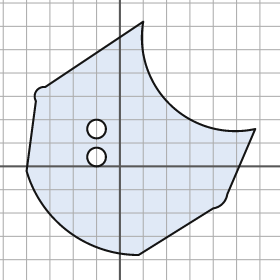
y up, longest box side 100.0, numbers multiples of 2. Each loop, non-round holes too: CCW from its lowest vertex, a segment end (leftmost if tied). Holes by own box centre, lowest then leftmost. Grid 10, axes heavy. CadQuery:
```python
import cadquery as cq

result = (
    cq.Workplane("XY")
    .moveTo(8.0, -38.0)
    .lineTo(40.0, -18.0)
    .threePointArc((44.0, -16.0), (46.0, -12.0))
    .lineTo(58.0, 16.0)
    .threePointArc((22.0, 26.0), (10.0, 62.0))
    .lineTo(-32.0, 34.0)
    .threePointArc((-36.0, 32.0), (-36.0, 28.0))
    .lineTo(-40.0, -2.0)
    .threePointArc((-22.0, -28.0), (8.0, -38.0))
    .close()
    .moveTo(-10.0, 4.0)
    .circle(4.0)
    .moveTo(-10.0, 16.0)
    .circle(4.0)
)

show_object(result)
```